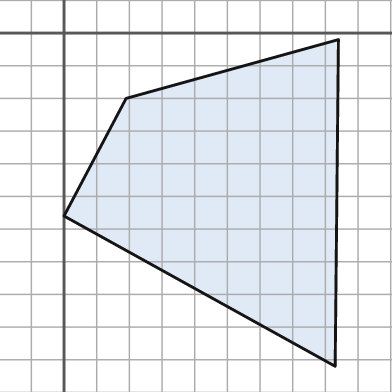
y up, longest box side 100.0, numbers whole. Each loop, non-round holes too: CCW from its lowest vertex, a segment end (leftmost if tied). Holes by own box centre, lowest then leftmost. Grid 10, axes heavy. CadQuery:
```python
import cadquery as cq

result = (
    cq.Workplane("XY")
    .moveTo(83.0, -102.0)
    .lineTo(84.0, -2.0)
    .lineTo(19.0, -20.0)
    .lineTo(0.0, -56.0)
    .close()
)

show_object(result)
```